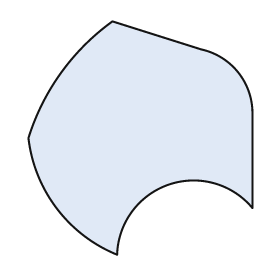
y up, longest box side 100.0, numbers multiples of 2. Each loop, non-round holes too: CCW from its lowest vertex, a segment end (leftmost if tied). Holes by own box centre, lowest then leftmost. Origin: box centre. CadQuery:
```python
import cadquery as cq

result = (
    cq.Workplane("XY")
    .moveTo(-10.0, -50.0)
    .threePointArc((12.0, -20.0), (48.0, -30.0))
    .lineTo(48.0, 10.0)
    .threePointArc((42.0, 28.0), (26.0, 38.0))
    .lineTo(-12.0, 50.0)
    .threePointArc((-34.0, 28.0), (-48.0, 0.0))
    .threePointArc((-36.0, -30.0), (-10.0, -50.0))
    .close()
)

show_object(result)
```